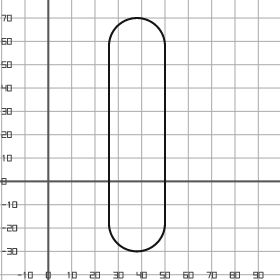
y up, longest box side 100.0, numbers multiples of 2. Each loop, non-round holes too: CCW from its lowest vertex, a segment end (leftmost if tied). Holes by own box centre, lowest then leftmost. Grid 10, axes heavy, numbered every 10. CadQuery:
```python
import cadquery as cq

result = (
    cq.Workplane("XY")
    .moveTo(26.0, -18.0)
    .threePointArc((38.0, -30.0), (50.0, -18.0))
    .lineTo(50.0, 58.0)
    .threePointArc((38.0, 70.0), (26.0, 58.0))
    .close()
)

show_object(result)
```